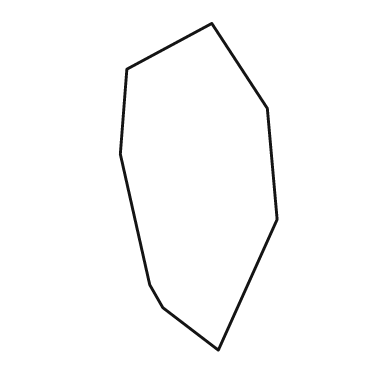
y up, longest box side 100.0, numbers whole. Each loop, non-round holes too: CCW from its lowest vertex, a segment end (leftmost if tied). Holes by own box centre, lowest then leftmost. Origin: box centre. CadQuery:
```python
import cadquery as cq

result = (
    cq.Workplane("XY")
    .moveTo(6.0, -50.0)
    .lineTo(24.0, -10.0)
    .lineTo(21.0, 24.0)
    .lineTo(4.0, 50.0)
    .lineTo(-22.0, 36.0)
    .lineTo(-24.0, 10.0)
    .lineTo(-15.0, -30.0)
    .lineTo(-11.0, -37.0)
    .close()
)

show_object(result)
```